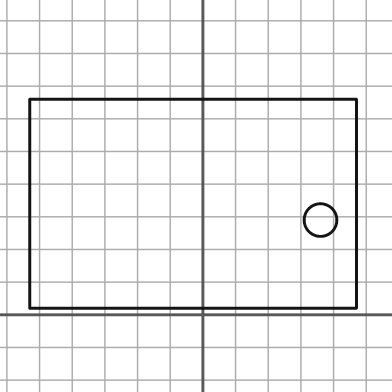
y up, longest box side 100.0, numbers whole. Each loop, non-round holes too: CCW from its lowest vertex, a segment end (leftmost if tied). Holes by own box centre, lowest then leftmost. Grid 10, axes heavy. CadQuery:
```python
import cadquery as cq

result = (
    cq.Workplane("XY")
    .moveTo(-53.0, 2.0)
    .lineTo(47.0, 2.0)
    .lineTo(47.0, 66.0)
    .lineTo(-53.0, 66.0)
    .close()
    .moveTo(36.0, 29.0)
    .circle(5.0)
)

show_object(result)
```